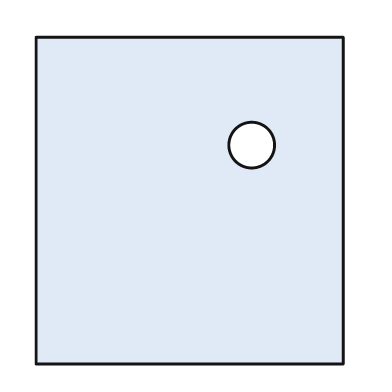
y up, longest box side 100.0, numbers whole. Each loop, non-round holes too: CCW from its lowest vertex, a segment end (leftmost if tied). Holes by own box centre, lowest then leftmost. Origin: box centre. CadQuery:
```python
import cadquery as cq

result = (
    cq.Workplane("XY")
    .moveTo(-47.0, -50.0)
    .lineTo(47.0, -50.0)
    .lineTo(47.0, 50.0)
    .lineTo(-47.0, 50.0)
    .close()
    .moveTo(19.0, 17.0)
    .circle(7.0)
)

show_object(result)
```